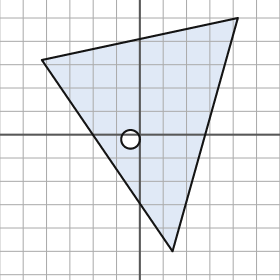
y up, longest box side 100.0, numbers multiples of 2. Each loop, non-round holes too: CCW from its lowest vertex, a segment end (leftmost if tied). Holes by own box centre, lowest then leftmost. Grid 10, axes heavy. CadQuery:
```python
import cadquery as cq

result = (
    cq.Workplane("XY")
    .moveTo(14.0, -50.0)
    .lineTo(42.0, 50.0)
    .lineTo(-42.0, 32.0)
    .close()
    .moveTo(-4.0, -2.0)
    .circle(4.0)
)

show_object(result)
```